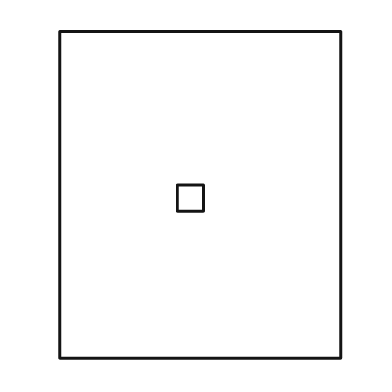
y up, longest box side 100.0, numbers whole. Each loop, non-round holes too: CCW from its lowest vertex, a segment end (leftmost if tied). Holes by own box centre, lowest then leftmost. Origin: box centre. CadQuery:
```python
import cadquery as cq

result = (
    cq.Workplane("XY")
    .moveTo(-43.0, -50.0)
    .lineTo(43.0, -50.0)
    .lineTo(43.0, 50.0)
    .lineTo(-43.0, 50.0)
    .close()
    .moveTo(-7.0, -5.0)
    .lineTo(1.0, -5.0)
    .lineTo(1.0, 3.0)
    .lineTo(-7.0, 3.0)
    .close()
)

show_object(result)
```